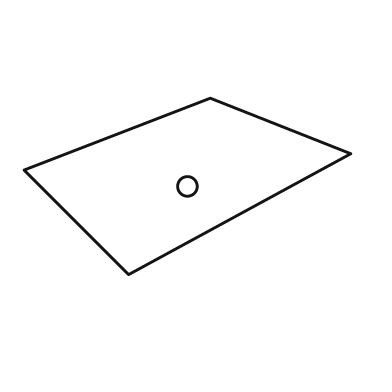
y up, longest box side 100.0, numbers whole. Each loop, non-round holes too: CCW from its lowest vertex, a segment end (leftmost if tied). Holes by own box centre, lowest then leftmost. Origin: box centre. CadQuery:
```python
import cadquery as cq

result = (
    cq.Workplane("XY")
    .moveTo(-18.0, -27.0)
    .lineTo(50.0, 10.0)
    .lineTo(7.0, 27.0)
    .lineTo(-50.0, 5.0)
    .close()
    .moveTo(0.0, 0.0)
    .circle(3.0)
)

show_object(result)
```